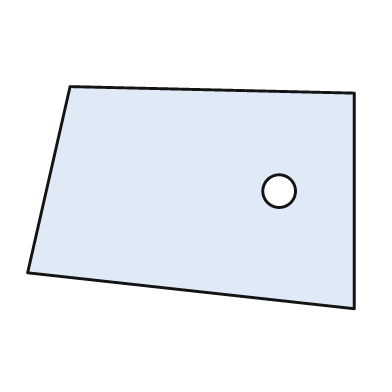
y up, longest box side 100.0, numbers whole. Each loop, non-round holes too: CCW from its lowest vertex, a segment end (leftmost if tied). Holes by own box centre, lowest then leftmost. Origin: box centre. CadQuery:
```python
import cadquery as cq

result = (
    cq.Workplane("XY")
    .moveTo(50.0, -34.0)
    .lineTo(50.0, 32.0)
    .lineTo(-37.0, 34.0)
    .lineTo(-50.0, -23.0)
    .close()
    .moveTo(27.0, 2.0)
    .circle(5.0)
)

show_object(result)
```